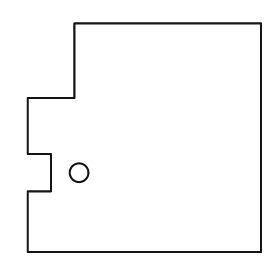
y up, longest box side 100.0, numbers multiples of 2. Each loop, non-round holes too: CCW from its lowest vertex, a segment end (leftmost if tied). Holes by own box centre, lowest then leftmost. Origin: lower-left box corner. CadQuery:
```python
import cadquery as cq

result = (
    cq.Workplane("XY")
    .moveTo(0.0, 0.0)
    .lineTo(100.0, 0.0)
    .lineTo(100.0, 98.0)
    .lineTo(20.0, 98.0)
    .lineTo(20.0, 66.0)
    .lineTo(0.0, 66.0)
    .lineTo(0.0, 42.0)
    .lineTo(10.0, 42.0)
    .lineTo(10.0, 26.0)
    .lineTo(0.0, 26.0)
    .close()
    .moveTo(22.0, 34.0)
    .circle(4.0)
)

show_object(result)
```